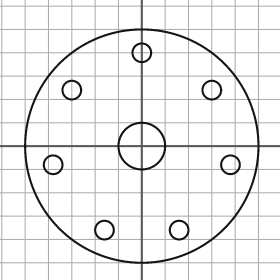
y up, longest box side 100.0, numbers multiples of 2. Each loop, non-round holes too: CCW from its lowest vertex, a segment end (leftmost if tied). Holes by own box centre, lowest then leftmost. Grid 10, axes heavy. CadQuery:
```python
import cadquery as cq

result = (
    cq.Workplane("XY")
    .moveTo(0.0, 0.0)
    .circle(50.0)
    .moveTo(-16.0, -36.0)
    .circle(4.0)
    .moveTo(16.0, -36.0)
    .circle(4.0)
    .moveTo(-38.0, -8.0)
    .circle(4.0)
    .moveTo(38.0, -8.0)
    .circle(4.0)
    .moveTo(0.0, 0.0)
    .circle(10.0)
    .moveTo(-30.0, 24.0)
    .circle(4.0)
    .moveTo(30.0, 24.0)
    .circle(4.0)
    .moveTo(0.0, 40.0)
    .circle(4.0)
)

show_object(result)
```